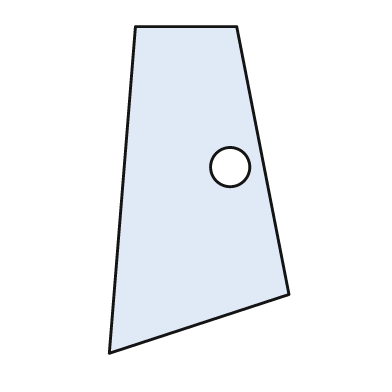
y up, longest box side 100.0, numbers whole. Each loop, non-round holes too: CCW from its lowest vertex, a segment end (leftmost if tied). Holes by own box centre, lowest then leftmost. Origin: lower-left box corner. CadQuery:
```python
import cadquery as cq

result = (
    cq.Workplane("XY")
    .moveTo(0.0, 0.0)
    .lineTo(55.0, 18.0)
    .lineTo(39.0, 100.0)
    .lineTo(8.0, 100.0)
    .close()
    .moveTo(37.0, 57.0)
    .circle(6.0)
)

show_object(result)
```